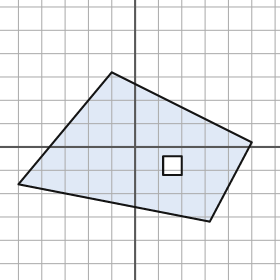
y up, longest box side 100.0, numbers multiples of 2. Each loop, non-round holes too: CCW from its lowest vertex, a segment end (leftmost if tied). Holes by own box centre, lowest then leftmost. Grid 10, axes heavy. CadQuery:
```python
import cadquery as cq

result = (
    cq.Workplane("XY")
    .moveTo(32.0, -32.0)
    .lineTo(50.0, 2.0)
    .lineTo(-10.0, 32.0)
    .lineTo(-50.0, -16.0)
    .close()
    .moveTo(12.0, -12.0)
    .lineTo(20.0, -12.0)
    .lineTo(20.0, -4.0)
    .lineTo(12.0, -4.0)
    .close()
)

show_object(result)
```